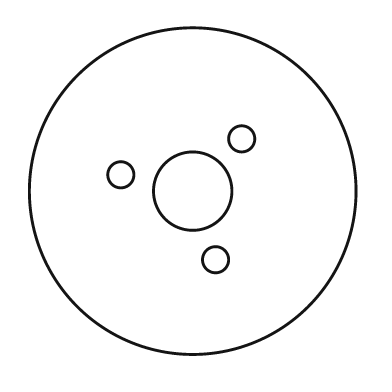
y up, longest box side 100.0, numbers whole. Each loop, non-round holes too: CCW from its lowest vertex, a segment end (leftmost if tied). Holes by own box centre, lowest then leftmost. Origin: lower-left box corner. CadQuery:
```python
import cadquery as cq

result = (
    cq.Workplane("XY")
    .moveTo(50.0, 50.0)
    .circle(50.0)
    .moveTo(57.0, 29.0)
    .circle(4.0)
    .moveTo(50.0, 50.0)
    .circle(12.0)
    .moveTo(28.0, 55.0)
    .circle(4.0)
    .moveTo(65.0, 66.0)
    .circle(4.0)
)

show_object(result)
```